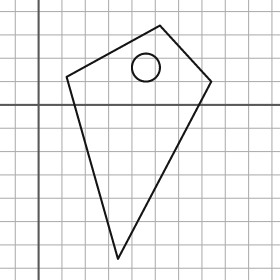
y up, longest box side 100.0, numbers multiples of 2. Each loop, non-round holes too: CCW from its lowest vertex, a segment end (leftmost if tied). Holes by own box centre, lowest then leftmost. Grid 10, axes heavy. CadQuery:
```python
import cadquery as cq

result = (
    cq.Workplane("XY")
    .moveTo(34.0, -66.0)
    .lineTo(74.0, 10.0)
    .lineTo(52.0, 34.0)
    .lineTo(12.0, 12.0)
    .close()
    .moveTo(46.0, 16.0)
    .circle(6.0)
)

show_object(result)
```